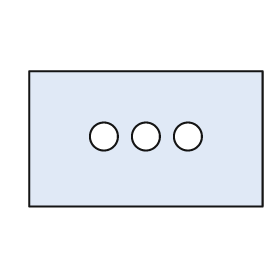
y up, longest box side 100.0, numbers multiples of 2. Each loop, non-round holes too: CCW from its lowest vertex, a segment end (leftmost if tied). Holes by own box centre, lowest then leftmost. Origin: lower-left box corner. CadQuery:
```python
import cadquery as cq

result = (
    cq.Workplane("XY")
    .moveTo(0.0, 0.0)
    .lineTo(100.0, 0.0)
    .lineTo(100.0, 58.0)
    .lineTo(0.0, 58.0)
    .close()
    .moveTo(32.0, 30.0)
    .circle(6.0)
    .moveTo(50.0, 30.0)
    .circle(6.0)
    .moveTo(68.0, 30.0)
    .circle(6.0)
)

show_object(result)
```